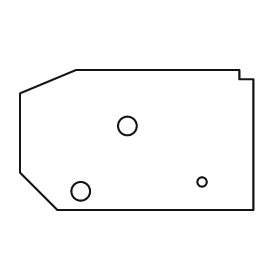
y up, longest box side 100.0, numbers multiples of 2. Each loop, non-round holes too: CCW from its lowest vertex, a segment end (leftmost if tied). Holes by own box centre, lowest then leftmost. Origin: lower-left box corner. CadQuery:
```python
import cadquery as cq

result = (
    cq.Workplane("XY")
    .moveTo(16.0, 0.0)
    .lineTo(100.0, 0.0)
    .lineTo(100.0, 56.0)
    .lineTo(94.0, 56.0)
    .lineTo(94.0, 60.0)
    .lineTo(24.0, 60.0)
    .lineTo(0.0, 50.0)
    .lineTo(0.0, 16.0)
    .close()
    .moveTo(26.0, 8.0)
    .circle(4.0)
    .moveTo(78.0, 12.0)
    .circle(2.0)
    .moveTo(46.0, 36.0)
    .circle(4.0)
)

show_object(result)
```